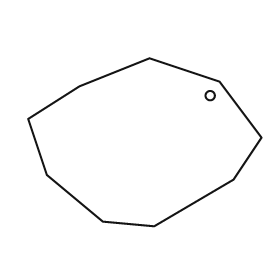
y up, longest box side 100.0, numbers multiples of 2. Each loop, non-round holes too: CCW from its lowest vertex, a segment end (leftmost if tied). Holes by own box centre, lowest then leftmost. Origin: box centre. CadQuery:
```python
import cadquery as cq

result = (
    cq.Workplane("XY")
    .moveTo(4.0, -36.0)
    .lineTo(38.0, -16.0)
    .lineTo(50.0, 2.0)
    .lineTo(32.0, 26.0)
    .lineTo(2.0, 36.0)
    .lineTo(-28.0, 24.0)
    .lineTo(-50.0, 10.0)
    .lineTo(-42.0, -14.0)
    .lineTo(-18.0, -34.0)
    .close()
    .moveTo(28.0, 20.0)
    .circle(2.0)
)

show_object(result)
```